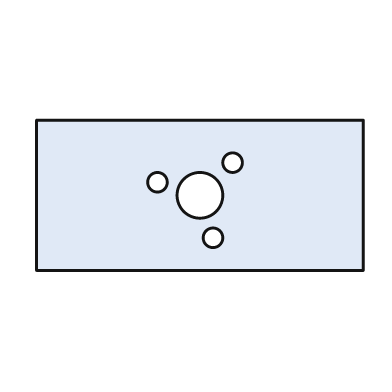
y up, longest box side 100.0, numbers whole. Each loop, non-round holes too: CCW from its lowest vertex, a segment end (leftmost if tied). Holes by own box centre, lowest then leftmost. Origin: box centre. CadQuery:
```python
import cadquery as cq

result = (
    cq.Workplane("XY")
    .moveTo(-50.0, -23.0)
    .lineTo(50.0, -23.0)
    .lineTo(50.0, 23.0)
    .lineTo(-50.0, 23.0)
    .close()
    .moveTo(4.0, -13.0)
    .circle(3.0)
    .moveTo(0.0, 0.0)
    .circle(7.0)
    .moveTo(-13.0, 4.0)
    .circle(3.0)
    .moveTo(10.0, 10.0)
    .circle(3.0)
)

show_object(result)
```